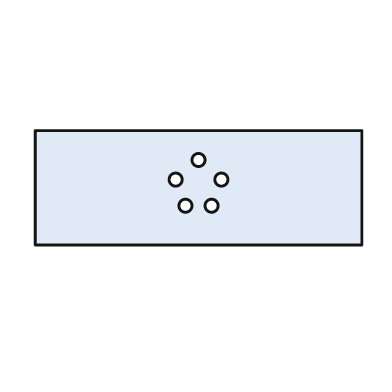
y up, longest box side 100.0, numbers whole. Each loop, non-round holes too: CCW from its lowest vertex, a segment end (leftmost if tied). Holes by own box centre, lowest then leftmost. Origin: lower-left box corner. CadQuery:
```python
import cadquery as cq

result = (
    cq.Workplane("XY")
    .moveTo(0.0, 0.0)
    .lineTo(100.0, 0.0)
    .lineTo(100.0, 35.0)
    .lineTo(0.0, 35.0)
    .close()
    .moveTo(46.0, 12.0)
    .circle(2.0)
    .moveTo(54.0, 12.0)
    .circle(2.0)
    .moveTo(43.0, 20.0)
    .circle(2.0)
    .moveTo(57.0, 20.0)
    .circle(2.0)
    .moveTo(50.0, 26.0)
    .circle(2.0)
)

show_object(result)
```